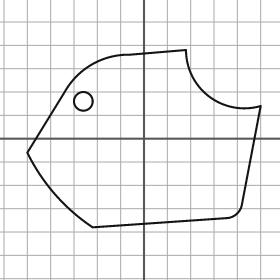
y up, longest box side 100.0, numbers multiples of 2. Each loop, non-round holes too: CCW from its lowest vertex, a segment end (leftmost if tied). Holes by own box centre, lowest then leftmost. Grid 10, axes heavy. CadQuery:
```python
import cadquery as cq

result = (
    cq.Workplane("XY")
    .moveTo(-22.0, -38.0)
    .lineTo(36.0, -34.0)
    .threePointArc((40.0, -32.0), (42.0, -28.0))
    .lineTo(50.0, 14.0)
    .threePointArc((28.0, 18.0), (18.0, 38.0))
    .lineTo(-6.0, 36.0)
    .threePointArc((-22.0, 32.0), (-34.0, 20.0))
    .lineTo(-50.0, -6.0)
    .threePointArc((-38.0, -24.0), (-22.0, -38.0))
    .close()
    .moveTo(-26.0, 16.0)
    .circle(4.0)
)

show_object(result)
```